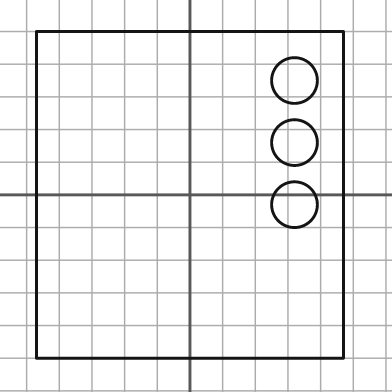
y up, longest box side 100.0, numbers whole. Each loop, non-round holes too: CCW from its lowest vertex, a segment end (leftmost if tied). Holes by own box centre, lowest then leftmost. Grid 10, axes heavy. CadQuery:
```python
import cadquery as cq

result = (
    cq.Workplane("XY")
    .moveTo(-47.0, -50.0)
    .lineTo(47.0, -50.0)
    .lineTo(47.0, 50.0)
    .lineTo(-47.0, 50.0)
    .close()
    .moveTo(32.0, -3.0)
    .circle(7.0)
    .moveTo(32.0, 16.0)
    .circle(7.0)
    .moveTo(32.0, 35.0)
    .circle(7.0)
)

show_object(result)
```